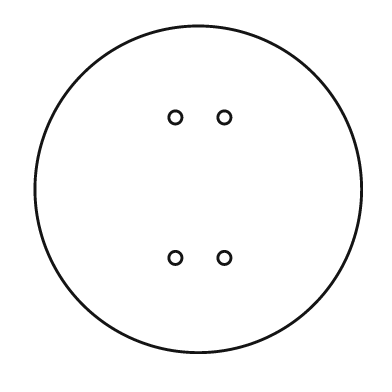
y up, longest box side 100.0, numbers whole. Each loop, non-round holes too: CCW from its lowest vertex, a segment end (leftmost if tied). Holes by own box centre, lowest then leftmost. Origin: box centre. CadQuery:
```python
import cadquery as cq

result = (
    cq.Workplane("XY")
    .moveTo(0.0, 0.0)
    .circle(50.0)
    .moveTo(-7.0, -21.0)
    .circle(2.0)
    .moveTo(8.0, -21.0)
    .circle(2.0)
    .moveTo(-7.0, 22.0)
    .circle(2.0)
    .moveTo(8.0, 22.0)
    .circle(2.0)
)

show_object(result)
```